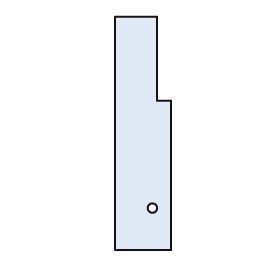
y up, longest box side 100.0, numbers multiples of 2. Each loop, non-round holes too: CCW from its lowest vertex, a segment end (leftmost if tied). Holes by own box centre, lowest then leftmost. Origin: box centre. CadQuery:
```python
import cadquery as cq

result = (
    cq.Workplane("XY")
    .moveTo(-12.0, -50.0)
    .lineTo(12.0, -50.0)
    .lineTo(12.0, 14.0)
    .lineTo(6.0, 14.0)
    .lineTo(6.0, 50.0)
    .lineTo(-12.0, 50.0)
    .close()
    .moveTo(4.0, -32.0)
    .circle(2.0)
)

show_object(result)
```